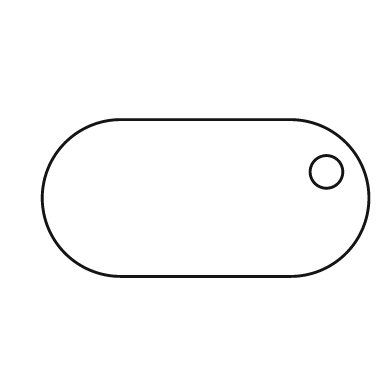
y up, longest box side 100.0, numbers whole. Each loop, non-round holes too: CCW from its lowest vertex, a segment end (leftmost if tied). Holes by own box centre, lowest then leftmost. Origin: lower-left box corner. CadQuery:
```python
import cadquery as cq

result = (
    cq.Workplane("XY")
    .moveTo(24.0, 0.0)
    .lineTo(76.0, 0.0)
    .threePointArc((100.0, 24.0), (76.0, 48.0))
    .lineTo(24.0, 48.0)
    .threePointArc((0.0, 24.0), (24.0, 0.0))
    .close()
    .moveTo(87.0, 32.0)
    .circle(5.0)
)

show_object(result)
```